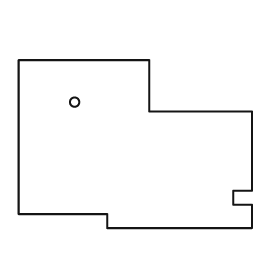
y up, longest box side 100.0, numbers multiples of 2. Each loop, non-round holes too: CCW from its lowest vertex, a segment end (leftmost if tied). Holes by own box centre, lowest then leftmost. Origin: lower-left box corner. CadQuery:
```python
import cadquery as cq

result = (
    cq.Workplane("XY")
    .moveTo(38.0, 0.0)
    .lineTo(100.0, 0.0)
    .lineTo(100.0, 10.0)
    .lineTo(92.0, 10.0)
    .lineTo(92.0, 16.0)
    .lineTo(100.0, 16.0)
    .lineTo(100.0, 50.0)
    .lineTo(56.0, 50.0)
    .lineTo(56.0, 72.0)
    .lineTo(0.0, 72.0)
    .lineTo(0.0, 6.0)
    .lineTo(38.0, 6.0)
    .close()
    .moveTo(24.0, 54.0)
    .circle(2.0)
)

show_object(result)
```